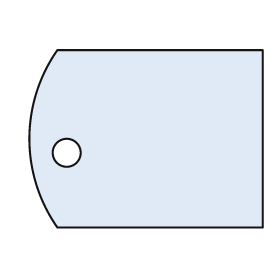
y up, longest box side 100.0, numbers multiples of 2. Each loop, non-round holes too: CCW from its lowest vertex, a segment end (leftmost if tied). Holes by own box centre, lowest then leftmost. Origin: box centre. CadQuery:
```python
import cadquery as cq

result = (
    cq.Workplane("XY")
    .moveTo(-38.0, -38.0)
    .lineTo(50.0, -38.0)
    .lineTo(50.0, 38.0)
    .lineTo(-38.0, 38.0)
    .threePointArc((-50.0, 0.0), (-38.0, -38.0))
    .close()
    .moveTo(-34.0, -6.0)
    .circle(6.0)
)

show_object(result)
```